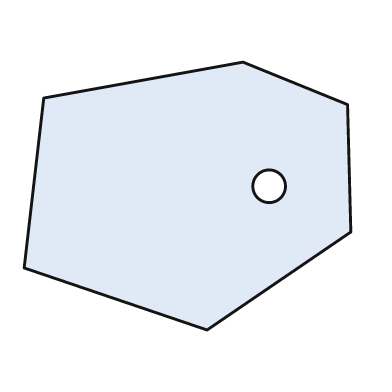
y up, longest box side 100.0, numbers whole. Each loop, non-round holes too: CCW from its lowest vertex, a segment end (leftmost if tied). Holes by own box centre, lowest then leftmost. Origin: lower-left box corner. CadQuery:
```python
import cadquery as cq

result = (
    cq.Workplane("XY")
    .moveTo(56.0, 0.0)
    .lineTo(100.0, 30.0)
    .lineTo(99.0, 69.0)
    .lineTo(67.0, 82.0)
    .lineTo(6.0, 71.0)
    .lineTo(0.0, 19.0)
    .close()
    .moveTo(75.0, 44.0)
    .circle(5.0)
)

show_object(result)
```